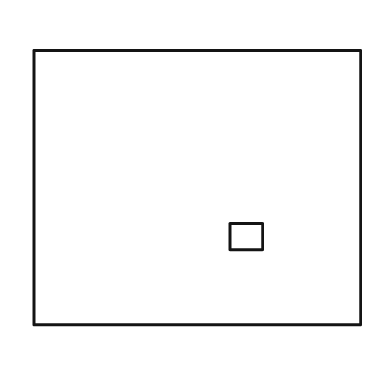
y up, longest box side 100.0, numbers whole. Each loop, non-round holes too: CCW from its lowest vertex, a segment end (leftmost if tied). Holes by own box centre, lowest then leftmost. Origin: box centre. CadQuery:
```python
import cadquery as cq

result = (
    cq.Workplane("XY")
    .moveTo(-50.0, -42.0)
    .lineTo(50.0, -42.0)
    .lineTo(50.0, 42.0)
    .lineTo(-50.0, 42.0)
    .close()
    .moveTo(10.0, -19.0)
    .lineTo(20.0, -19.0)
    .lineTo(20.0, -11.0)
    .lineTo(10.0, -11.0)
    .close()
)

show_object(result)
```